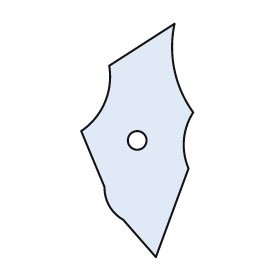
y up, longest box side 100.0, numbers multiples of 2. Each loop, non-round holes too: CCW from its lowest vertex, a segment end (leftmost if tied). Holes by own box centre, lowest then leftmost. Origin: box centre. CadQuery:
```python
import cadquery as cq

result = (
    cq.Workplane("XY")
    .moveTo(8.0, -50.0)
    .lineTo(22.0, -12.0)
    .threePointArc((20.0, 0.0), (24.0, 12.0))
    .threePointArc((16.0, 30.0), (16.0, 50.0))
    .lineTo(-12.0, 32.0)
    .threePointArc((-14.0, 16.0), (-24.0, 4.0))
    .lineTo(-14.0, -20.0)
    .threePointArc((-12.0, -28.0), (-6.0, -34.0))
    .close()
    .moveTo(0.0, 0.0)
    .circle(4.0)
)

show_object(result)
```